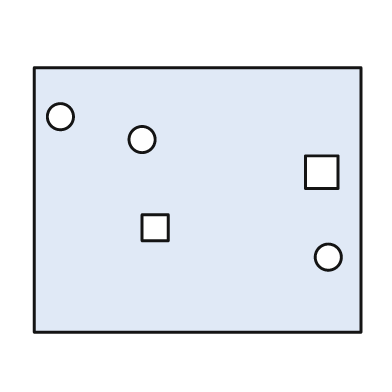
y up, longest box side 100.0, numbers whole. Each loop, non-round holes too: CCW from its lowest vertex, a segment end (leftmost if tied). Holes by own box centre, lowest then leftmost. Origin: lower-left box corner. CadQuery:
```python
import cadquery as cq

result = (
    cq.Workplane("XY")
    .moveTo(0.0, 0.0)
    .lineTo(100.0, 0.0)
    .lineTo(100.0, 81.0)
    .lineTo(0.0, 81.0)
    .close()
    .moveTo(90.0, 23.0)
    .circle(4.0)
    .moveTo(33.0, 28.0)
    .lineTo(41.0, 28.0)
    .lineTo(41.0, 36.0)
    .lineTo(33.0, 36.0)
    .close()
    .moveTo(83.0, 44.0)
    .lineTo(93.0, 44.0)
    .lineTo(93.0, 54.0)
    .lineTo(83.0, 54.0)
    .close()
    .moveTo(33.0, 59.0)
    .circle(4.0)
    .moveTo(8.0, 66.0)
    .circle(4.0)
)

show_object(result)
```